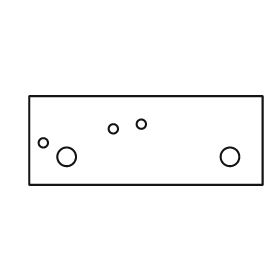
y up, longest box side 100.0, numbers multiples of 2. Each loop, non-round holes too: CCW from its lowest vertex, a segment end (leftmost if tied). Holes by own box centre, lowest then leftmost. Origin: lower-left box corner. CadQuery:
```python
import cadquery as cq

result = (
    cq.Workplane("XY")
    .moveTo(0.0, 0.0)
    .lineTo(100.0, 0.0)
    .lineTo(100.0, 38.0)
    .lineTo(0.0, 38.0)
    .close()
    .moveTo(16.0, 12.0)
    .circle(4.0)
    .moveTo(86.0, 12.0)
    .circle(4.0)
    .moveTo(6.0, 18.0)
    .circle(2.0)
    .moveTo(36.0, 24.0)
    .circle(2.0)
    .moveTo(48.0, 26.0)
    .circle(2.0)
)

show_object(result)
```